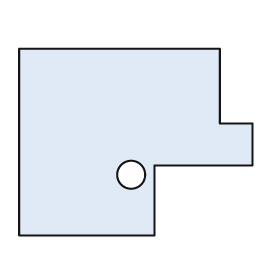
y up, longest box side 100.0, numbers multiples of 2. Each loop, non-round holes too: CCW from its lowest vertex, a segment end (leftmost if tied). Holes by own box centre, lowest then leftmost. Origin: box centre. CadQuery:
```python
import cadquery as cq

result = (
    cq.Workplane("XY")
    .moveTo(-50.0, -40.0)
    .lineTo(8.0, -40.0)
    .lineTo(8.0, -10.0)
    .lineTo(50.0, -10.0)
    .lineTo(50.0, 8.0)
    .lineTo(36.0, 8.0)
    .lineTo(36.0, 40.0)
    .lineTo(-50.0, 40.0)
    .close()
    .moveTo(-2.0, -14.0)
    .circle(6.0)
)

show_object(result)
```